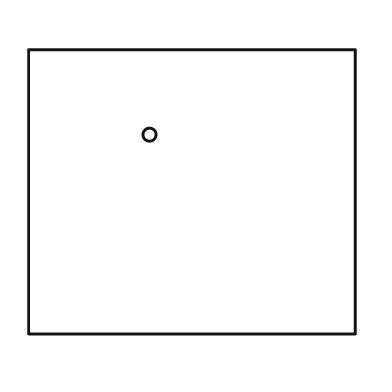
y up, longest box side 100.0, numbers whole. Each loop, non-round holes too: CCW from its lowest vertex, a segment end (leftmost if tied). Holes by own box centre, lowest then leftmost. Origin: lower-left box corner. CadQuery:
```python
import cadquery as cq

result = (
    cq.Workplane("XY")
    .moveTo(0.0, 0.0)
    .lineTo(100.0, 0.0)
    .lineTo(100.0, 87.0)
    .lineTo(0.0, 87.0)
    .close()
    .moveTo(37.0, 61.0)
    .circle(2.0)
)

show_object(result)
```